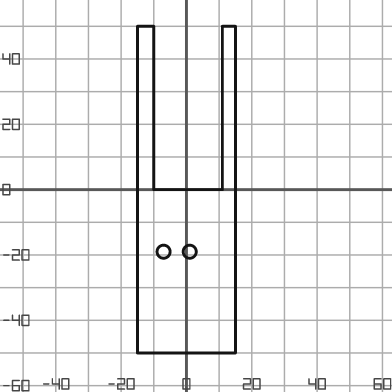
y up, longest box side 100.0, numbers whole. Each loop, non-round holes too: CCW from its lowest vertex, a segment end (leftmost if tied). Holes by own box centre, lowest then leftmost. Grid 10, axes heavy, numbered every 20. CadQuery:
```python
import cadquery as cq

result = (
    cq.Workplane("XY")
    .moveTo(-15.0, -50.0)
    .lineTo(15.0, -50.0)
    .lineTo(15.0, 50.0)
    .lineTo(11.0, 50.0)
    .lineTo(11.0, 0.0)
    .lineTo(-10.0, 0.0)
    .lineTo(-10.0, 50.0)
    .lineTo(-15.0, 50.0)
    .close()
    .moveTo(-7.0, -19.0)
    .circle(2.0)
    .moveTo(1.0, -19.0)
    .circle(2.0)
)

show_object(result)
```